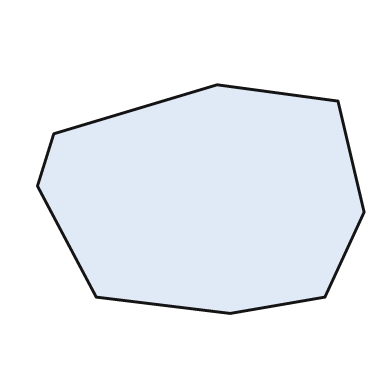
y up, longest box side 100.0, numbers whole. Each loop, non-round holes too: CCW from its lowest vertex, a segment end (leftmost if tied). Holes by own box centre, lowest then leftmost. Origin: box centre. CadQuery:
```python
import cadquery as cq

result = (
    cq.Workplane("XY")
    .moveTo(9.0, -35.0)
    .lineTo(38.0, -30.0)
    .lineTo(50.0, -4.0)
    .lineTo(42.0, 30.0)
    .lineTo(5.0, 35.0)
    .lineTo(-45.0, 20.0)
    .lineTo(-50.0, 4.0)
    .lineTo(-32.0, -30.0)
    .close()
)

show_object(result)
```